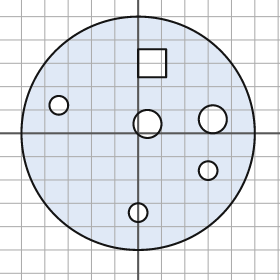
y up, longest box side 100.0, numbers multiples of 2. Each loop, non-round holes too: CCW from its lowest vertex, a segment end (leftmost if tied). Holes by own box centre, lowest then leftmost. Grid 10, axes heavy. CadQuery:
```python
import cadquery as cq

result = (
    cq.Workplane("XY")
    .moveTo(0.0, 0.0)
    .circle(50.0)
    .moveTo(0.0, -34.0)
    .circle(4.0)
    .moveTo(30.0, -16.0)
    .circle(4.0)
    .moveTo(4.0, 4.0)
    .circle(6.0)
    .moveTo(32.0, 6.0)
    .circle(6.0)
    .moveTo(-34.0, 12.0)
    .circle(4.0)
    .moveTo(0.0, 24.0)
    .lineTo(12.0, 24.0)
    .lineTo(12.0, 36.0)
    .lineTo(0.0, 36.0)
    .close()
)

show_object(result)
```